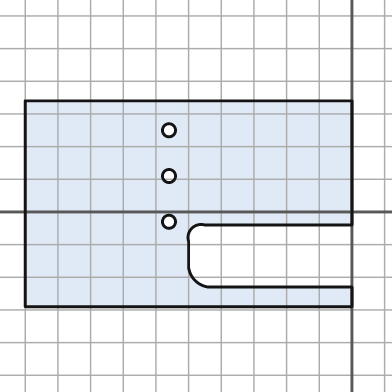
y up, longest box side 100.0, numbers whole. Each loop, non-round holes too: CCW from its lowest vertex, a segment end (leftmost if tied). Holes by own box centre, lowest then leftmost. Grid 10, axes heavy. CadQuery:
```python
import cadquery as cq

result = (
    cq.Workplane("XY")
    .moveTo(-100.0, -29.0)
    .lineTo(0.0, -29.0)
    .lineTo(0.0, -23.0)
    .lineTo(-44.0, -23.0)
    .threePointArc((-48.0, -21.0), (-50.0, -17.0))
    .lineTo(-50.0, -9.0)
    .threePointArc((-49.0, -5.0), (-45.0, -4.0))
    .lineTo(0.0, -4.0)
    .lineTo(0.0, 34.0)
    .lineTo(-100.0, 34.0)
    .close()
    .moveTo(-56.0, -3.0)
    .circle(2.0)
    .moveTo(-56.0, 11.0)
    .circle(2.0)
    .moveTo(-56.0, 25.0)
    .circle(2.0)
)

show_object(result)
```